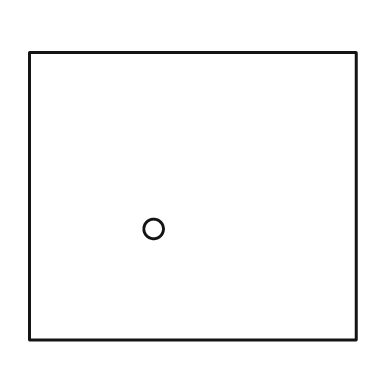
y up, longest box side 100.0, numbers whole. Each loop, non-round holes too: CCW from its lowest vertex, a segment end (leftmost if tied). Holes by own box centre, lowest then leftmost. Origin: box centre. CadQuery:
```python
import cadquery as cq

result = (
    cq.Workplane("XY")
    .moveTo(-50.0, -44.0)
    .lineTo(50.0, -44.0)
    .lineTo(50.0, 44.0)
    .lineTo(-50.0, 44.0)
    .close()
    .moveTo(-12.0, -10.0)
    .circle(3.0)
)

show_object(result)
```